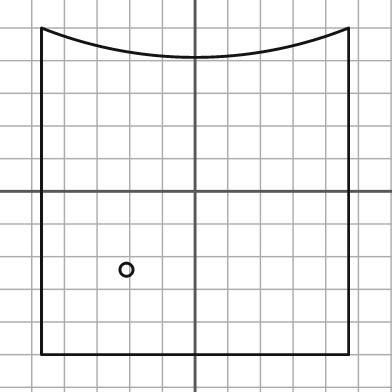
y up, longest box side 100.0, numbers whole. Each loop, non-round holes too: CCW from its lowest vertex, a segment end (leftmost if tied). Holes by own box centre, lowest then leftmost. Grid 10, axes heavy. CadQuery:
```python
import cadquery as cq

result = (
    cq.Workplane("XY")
    .moveTo(-47.0, -50.0)
    .lineTo(47.0, -50.0)
    .lineTo(47.0, 50.0)
    .threePointArc((0.0, 41.0), (-47.0, 50.0))
    .close()
    .moveTo(-21.0, -24.0)
    .circle(2.0)
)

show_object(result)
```